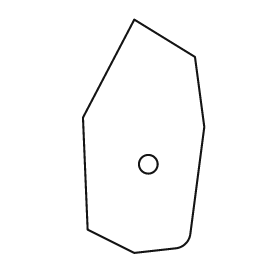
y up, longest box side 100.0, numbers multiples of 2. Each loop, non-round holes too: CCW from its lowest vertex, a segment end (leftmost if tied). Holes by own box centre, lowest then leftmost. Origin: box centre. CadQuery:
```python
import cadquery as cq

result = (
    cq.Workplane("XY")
    .moveTo(-4.0, -50.0)
    .lineTo(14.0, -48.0)
    .threePointArc((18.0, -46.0), (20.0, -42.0))
    .lineTo(26.0, 4.0)
    .lineTo(22.0, 34.0)
    .lineTo(-4.0, 50.0)
    .lineTo(-26.0, 8.0)
    .lineTo(-24.0, -40.0)
    .close()
    .moveTo(2.0, -12.0)
    .circle(4.0)
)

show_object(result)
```